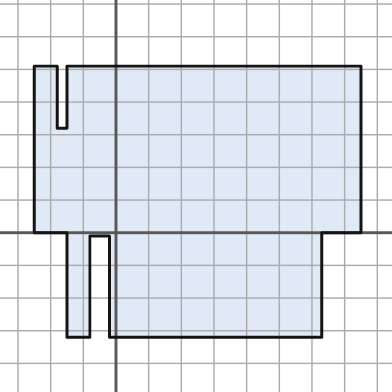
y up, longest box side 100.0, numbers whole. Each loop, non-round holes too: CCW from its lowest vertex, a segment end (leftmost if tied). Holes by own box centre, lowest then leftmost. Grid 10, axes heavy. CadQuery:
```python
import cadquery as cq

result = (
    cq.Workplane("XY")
    .moveTo(-15.0, -32.0)
    .lineTo(-8.0, -32.0)
    .lineTo(-8.0, -1.0)
    .lineTo(-2.0, -1.0)
    .lineTo(-2.0, -32.0)
    .lineTo(63.0, -32.0)
    .lineTo(63.0, 0.0)
    .lineTo(75.0, 0.0)
    .lineTo(75.0, 51.0)
    .lineTo(-15.0, 51.0)
    .lineTo(-15.0, 32.0)
    .lineTo(-18.0, 32.0)
    .lineTo(-18.0, 51.0)
    .lineTo(-25.0, 51.0)
    .lineTo(-25.0, 0.0)
    .lineTo(-15.0, 0.0)
    .close()
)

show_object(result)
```